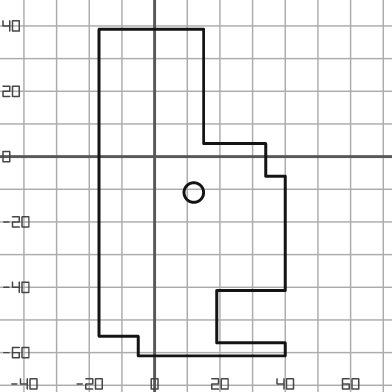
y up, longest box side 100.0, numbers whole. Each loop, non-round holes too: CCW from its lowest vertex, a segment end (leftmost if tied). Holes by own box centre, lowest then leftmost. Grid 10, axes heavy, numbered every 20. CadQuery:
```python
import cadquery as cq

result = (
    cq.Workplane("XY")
    .moveTo(-5.0, -61.0)
    .lineTo(40.0, -61.0)
    .lineTo(40.0, -57.0)
    .lineTo(19.0, -57.0)
    .lineTo(19.0, -41.0)
    .lineTo(40.0, -41.0)
    .lineTo(40.0, -6.0)
    .lineTo(34.0, -6.0)
    .lineTo(34.0, 4.0)
    .lineTo(15.0, 4.0)
    .lineTo(15.0, 39.0)
    .lineTo(-17.0, 39.0)
    .lineTo(-17.0, -55.0)
    .lineTo(-5.0, -55.0)
    .close()
    .moveTo(12.0, -11.0)
    .circle(3.0)
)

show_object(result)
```